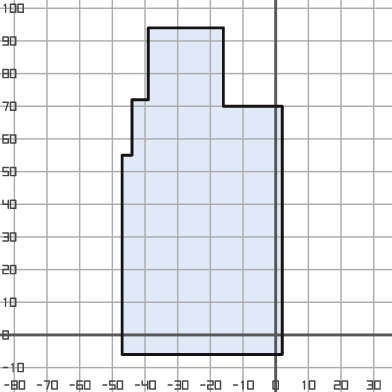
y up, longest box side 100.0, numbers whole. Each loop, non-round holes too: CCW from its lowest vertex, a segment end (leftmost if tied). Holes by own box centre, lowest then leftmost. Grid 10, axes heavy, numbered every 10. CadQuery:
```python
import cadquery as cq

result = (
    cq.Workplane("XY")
    .moveTo(-47.0, -6.0)
    .lineTo(2.0, -6.0)
    .lineTo(2.0, 70.0)
    .lineTo(-16.0, 70.0)
    .lineTo(-16.0, 94.0)
    .lineTo(-39.0, 94.0)
    .lineTo(-39.0, 72.0)
    .lineTo(-44.0, 72.0)
    .lineTo(-44.0, 55.0)
    .lineTo(-47.0, 55.0)
    .close()
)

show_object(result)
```